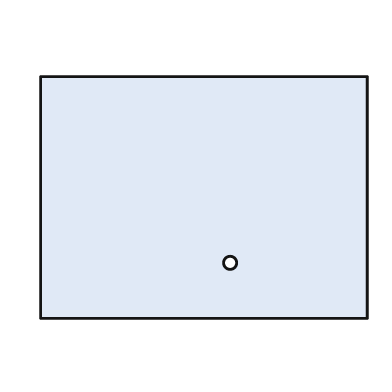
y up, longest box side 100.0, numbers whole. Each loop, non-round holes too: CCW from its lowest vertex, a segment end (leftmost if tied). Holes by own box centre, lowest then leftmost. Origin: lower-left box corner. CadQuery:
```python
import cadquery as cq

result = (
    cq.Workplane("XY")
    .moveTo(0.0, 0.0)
    .lineTo(100.0, 0.0)
    .lineTo(100.0, 74.0)
    .lineTo(0.0, 74.0)
    .close()
    .moveTo(58.0, 17.0)
    .circle(2.0)
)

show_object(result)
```